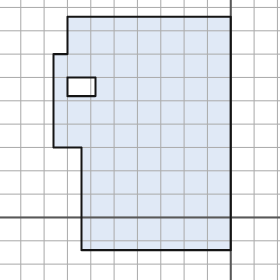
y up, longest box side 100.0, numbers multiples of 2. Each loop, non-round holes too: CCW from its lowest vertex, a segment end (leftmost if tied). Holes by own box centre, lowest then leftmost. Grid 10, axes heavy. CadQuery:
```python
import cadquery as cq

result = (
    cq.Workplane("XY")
    .moveTo(-64.0, -14.0)
    .lineTo(0.0, -14.0)
    .lineTo(0.0, 86.0)
    .lineTo(-70.0, 86.0)
    .lineTo(-70.0, 70.0)
    .lineTo(-76.0, 70.0)
    .lineTo(-76.0, 30.0)
    .lineTo(-64.0, 30.0)
    .close()
    .moveTo(-70.0, 52.0)
    .lineTo(-58.0, 52.0)
    .lineTo(-58.0, 60.0)
    .lineTo(-70.0, 60.0)
    .close()
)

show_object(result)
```